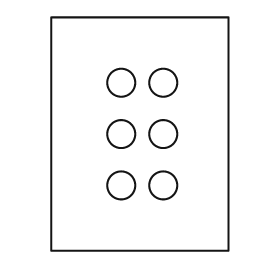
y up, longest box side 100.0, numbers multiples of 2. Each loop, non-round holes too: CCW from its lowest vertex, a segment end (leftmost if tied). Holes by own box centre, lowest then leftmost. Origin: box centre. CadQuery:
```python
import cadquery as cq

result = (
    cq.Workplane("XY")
    .moveTo(-38.0, -50.0)
    .lineTo(38.0, -50.0)
    .lineTo(38.0, 50.0)
    .lineTo(-38.0, 50.0)
    .close()
    .moveTo(-8.0, -22.0)
    .circle(6.0)
    .moveTo(10.0, -22.0)
    .circle(6.0)
    .moveTo(-8.0, 0.0)
    .circle(6.0)
    .moveTo(10.0, 0.0)
    .circle(6.0)
    .moveTo(-8.0, 22.0)
    .circle(6.0)
    .moveTo(10.0, 22.0)
    .circle(6.0)
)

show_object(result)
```